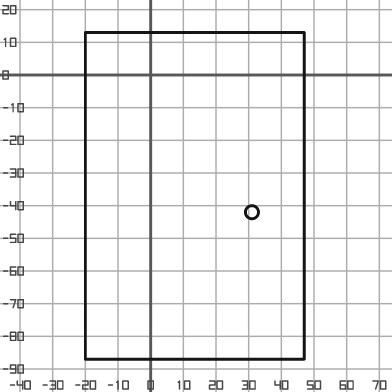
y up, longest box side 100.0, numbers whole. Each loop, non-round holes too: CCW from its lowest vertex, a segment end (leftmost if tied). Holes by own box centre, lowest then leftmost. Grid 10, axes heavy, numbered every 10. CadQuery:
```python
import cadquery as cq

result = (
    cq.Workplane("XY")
    .moveTo(-20.0, -87.0)
    .lineTo(47.0, -87.0)
    .lineTo(47.0, 13.0)
    .lineTo(-20.0, 13.0)
    .close()
    .moveTo(31.0, -42.0)
    .circle(2.0)
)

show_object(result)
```